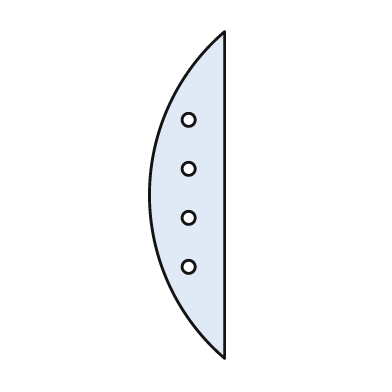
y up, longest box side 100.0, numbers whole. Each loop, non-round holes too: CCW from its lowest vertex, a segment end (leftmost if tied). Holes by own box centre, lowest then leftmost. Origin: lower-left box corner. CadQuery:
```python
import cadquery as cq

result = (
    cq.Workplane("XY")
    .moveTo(23.0, 0.0)
    .lineTo(23.0, 100.0)
    .threePointArc((0.0, 50.0), (23.0, 0.0))
    .close()
    .moveTo(12.0, 28.0)
    .circle(2.0)
    .moveTo(12.0, 43.0)
    .circle(2.0)
    .moveTo(12.0, 58.0)
    .circle(2.0)
    .moveTo(12.0, 73.0)
    .circle(2.0)
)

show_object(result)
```